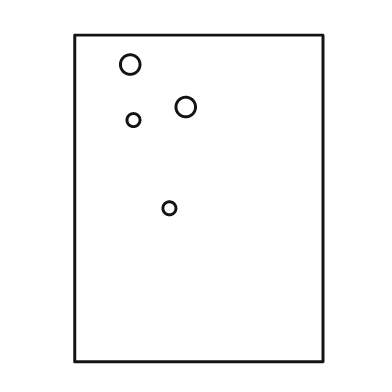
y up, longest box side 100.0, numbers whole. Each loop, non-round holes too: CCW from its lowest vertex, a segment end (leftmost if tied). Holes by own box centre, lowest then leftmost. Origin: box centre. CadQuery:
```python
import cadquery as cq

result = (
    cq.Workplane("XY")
    .moveTo(-38.0, -50.0)
    .lineTo(38.0, -50.0)
    .lineTo(38.0, 50.0)
    .lineTo(-38.0, 50.0)
    .close()
    .moveTo(-9.0, -3.0)
    .circle(2.0)
    .moveTo(-20.0, 24.0)
    .circle(2.0)
    .moveTo(-4.0, 28.0)
    .circle(3.0)
    .moveTo(-21.0, 41.0)
    .circle(3.0)
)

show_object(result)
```